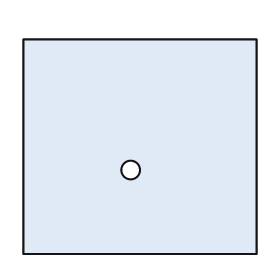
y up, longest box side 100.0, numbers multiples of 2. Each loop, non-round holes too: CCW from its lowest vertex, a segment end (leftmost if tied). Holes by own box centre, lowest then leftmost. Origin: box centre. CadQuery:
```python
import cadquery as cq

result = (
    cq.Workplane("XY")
    .moveTo(-50.0, -46.0)
    .lineTo(50.0, -46.0)
    .lineTo(50.0, 46.0)
    .lineTo(-50.0, 46.0)
    .close()
    .moveTo(-4.0, -10.0)
    .circle(4.0)
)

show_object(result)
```